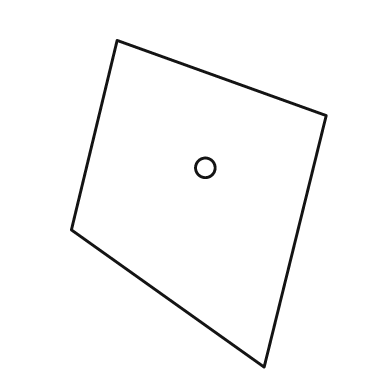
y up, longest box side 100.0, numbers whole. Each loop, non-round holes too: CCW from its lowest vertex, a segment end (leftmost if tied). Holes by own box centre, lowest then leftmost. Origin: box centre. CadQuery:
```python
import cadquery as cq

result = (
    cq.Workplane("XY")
    .moveTo(20.0, -50.0)
    .lineTo(39.0, 27.0)
    .lineTo(-25.0, 50.0)
    .lineTo(-39.0, -8.0)
    .close()
    .moveTo(2.0, 11.0)
    .circle(3.0)
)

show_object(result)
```